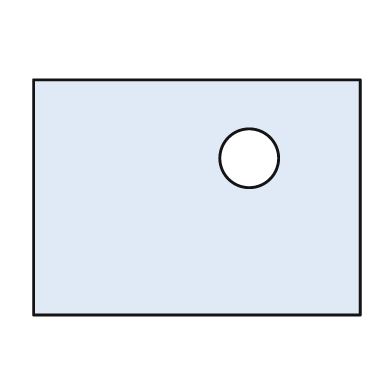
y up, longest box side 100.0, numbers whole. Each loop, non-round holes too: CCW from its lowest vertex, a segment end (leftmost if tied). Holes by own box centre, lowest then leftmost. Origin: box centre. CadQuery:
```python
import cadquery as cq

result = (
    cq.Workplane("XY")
    .moveTo(-50.0, -36.0)
    .lineTo(50.0, -36.0)
    .lineTo(50.0, 36.0)
    .lineTo(-50.0, 36.0)
    .close()
    .moveTo(16.0, 12.0)
    .circle(9.0)
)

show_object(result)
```